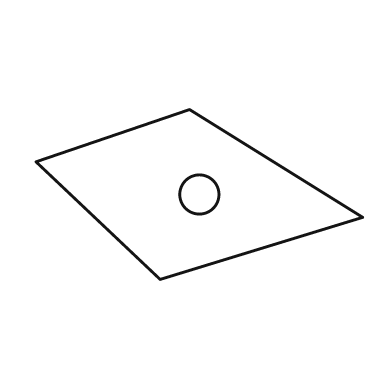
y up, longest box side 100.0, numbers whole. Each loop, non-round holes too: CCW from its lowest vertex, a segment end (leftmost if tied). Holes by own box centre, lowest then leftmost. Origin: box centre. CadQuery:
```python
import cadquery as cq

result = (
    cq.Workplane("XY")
    .moveTo(-12.0, -26.0)
    .lineTo(50.0, -7.0)
    .lineTo(-3.0, 26.0)
    .lineTo(-50.0, 10.0)
    .close()
    .moveTo(0.0, 0.0)
    .circle(6.0)
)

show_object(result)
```